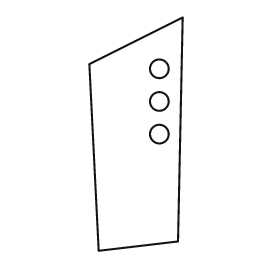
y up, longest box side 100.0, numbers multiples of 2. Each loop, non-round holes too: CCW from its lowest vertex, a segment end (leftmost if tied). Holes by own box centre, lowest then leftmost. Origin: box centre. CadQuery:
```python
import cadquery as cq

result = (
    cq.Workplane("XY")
    .moveTo(-16.0, -50.0)
    .lineTo(18.0, -46.0)
    .lineTo(20.0, 50.0)
    .lineTo(-20.0, 30.0)
    .close()
    .moveTo(10.0, 0.0)
    .circle(4.0)
    .moveTo(10.0, 14.0)
    .circle(4.0)
    .moveTo(10.0, 28.0)
    .circle(4.0)
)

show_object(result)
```